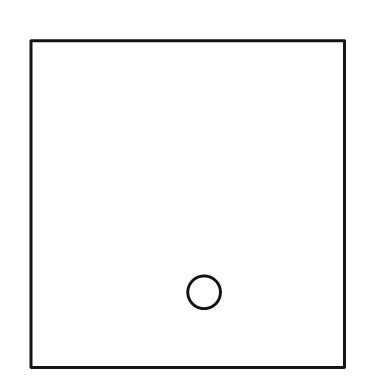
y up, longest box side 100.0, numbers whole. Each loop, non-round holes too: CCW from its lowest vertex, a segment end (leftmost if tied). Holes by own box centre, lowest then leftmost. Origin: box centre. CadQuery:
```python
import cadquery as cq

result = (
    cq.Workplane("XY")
    .moveTo(-48.0, -50.0)
    .lineTo(48.0, -50.0)
    .lineTo(48.0, 50.0)
    .lineTo(-48.0, 50.0)
    .close()
    .moveTo(5.0, -27.0)
    .circle(5.0)
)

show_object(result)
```